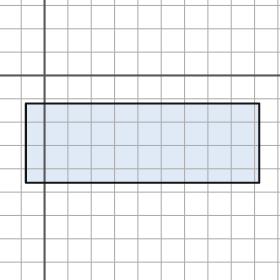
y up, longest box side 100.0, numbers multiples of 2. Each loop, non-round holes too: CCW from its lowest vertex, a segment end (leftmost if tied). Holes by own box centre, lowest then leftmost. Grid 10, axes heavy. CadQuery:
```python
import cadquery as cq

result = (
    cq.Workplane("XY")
    .moveTo(-8.0, -46.0)
    .lineTo(92.0, -46.0)
    .lineTo(92.0, -12.0)
    .lineTo(-8.0, -12.0)
    .close()
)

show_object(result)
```